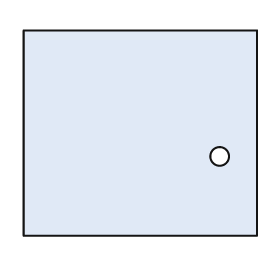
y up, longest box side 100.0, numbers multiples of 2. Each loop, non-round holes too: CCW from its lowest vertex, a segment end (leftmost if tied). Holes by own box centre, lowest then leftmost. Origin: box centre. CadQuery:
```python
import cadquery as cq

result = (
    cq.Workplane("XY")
    .moveTo(-50.0, -44.0)
    .lineTo(50.0, -44.0)
    .lineTo(50.0, 44.0)
    .lineTo(-50.0, 44.0)
    .close()
    .moveTo(34.0, -10.0)
    .circle(4.0)
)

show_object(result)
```